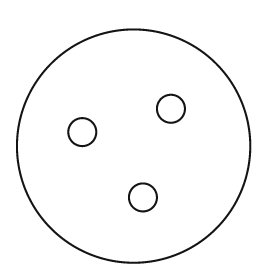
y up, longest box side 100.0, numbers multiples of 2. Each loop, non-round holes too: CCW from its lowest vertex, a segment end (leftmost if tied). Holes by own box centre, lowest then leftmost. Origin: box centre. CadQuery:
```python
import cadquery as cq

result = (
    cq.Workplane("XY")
    .moveTo(0.0, 0.0)
    .circle(50.0)
    .moveTo(4.0, -22.0)
    .circle(6.0)
    .moveTo(-22.0, 6.0)
    .circle(6.0)
    .moveTo(16.0, 16.0)
    .circle(6.0)
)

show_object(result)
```